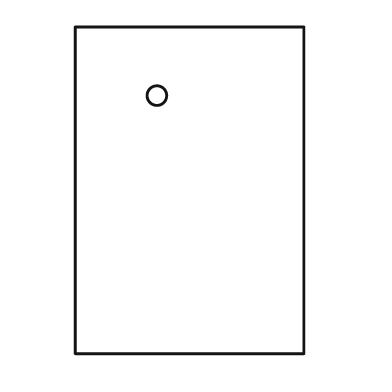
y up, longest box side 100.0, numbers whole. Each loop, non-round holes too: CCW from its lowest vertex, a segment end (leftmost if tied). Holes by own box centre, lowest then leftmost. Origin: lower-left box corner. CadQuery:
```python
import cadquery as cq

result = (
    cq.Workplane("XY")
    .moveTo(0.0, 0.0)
    .lineTo(70.0, 0.0)
    .lineTo(70.0, 100.0)
    .lineTo(0.0, 100.0)
    .close()
    .moveTo(25.0, 79.0)
    .circle(3.0)
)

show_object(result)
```